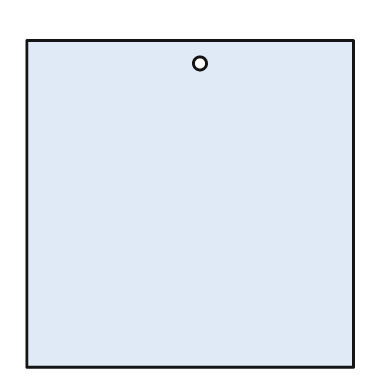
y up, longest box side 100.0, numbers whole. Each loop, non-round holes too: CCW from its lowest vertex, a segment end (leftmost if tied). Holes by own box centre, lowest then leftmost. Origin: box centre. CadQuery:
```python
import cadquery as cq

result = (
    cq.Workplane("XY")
    .moveTo(-50.0, -50.0)
    .lineTo(50.0, -50.0)
    .lineTo(50.0, 50.0)
    .lineTo(-50.0, 50.0)
    .close()
    .moveTo(3.0, 43.0)
    .circle(2.0)
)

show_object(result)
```